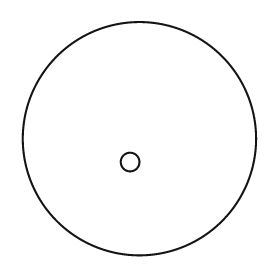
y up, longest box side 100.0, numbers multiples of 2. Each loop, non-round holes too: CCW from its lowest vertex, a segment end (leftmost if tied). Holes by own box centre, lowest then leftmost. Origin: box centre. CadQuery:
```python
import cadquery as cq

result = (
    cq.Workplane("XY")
    .moveTo(0.0, 0.0)
    .circle(50.0)
    .moveTo(-4.0, -10.0)
    .circle(4.0)
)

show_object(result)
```